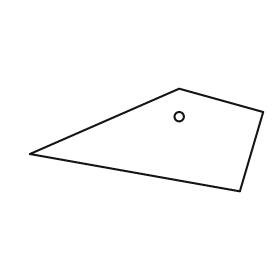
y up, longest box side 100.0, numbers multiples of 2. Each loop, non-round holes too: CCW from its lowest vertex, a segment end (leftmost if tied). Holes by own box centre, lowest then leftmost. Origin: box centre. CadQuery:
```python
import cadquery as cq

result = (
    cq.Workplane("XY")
    .moveTo(40.0, -22.0)
    .lineTo(50.0, 12.0)
    .lineTo(14.0, 22.0)
    .lineTo(-50.0, -6.0)
    .close()
    .moveTo(14.0, 10.0)
    .circle(2.0)
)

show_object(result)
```